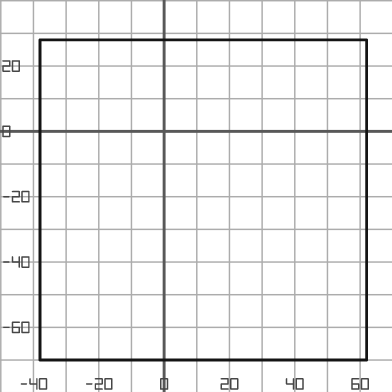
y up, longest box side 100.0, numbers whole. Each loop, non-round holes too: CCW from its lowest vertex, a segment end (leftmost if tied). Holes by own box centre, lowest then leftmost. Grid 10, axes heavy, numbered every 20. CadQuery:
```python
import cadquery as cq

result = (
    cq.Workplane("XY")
    .moveTo(-38.0, -70.0)
    .lineTo(62.0, -70.0)
    .lineTo(62.0, 28.0)
    .lineTo(-38.0, 28.0)
    .close()
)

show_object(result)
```